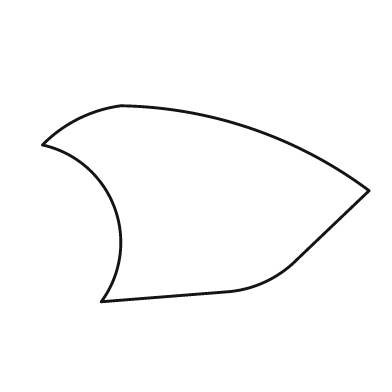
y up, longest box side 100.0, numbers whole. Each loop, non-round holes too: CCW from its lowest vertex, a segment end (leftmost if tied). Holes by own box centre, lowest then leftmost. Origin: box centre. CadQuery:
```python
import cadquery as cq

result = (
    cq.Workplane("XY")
    .moveTo(-32.0, -30.0)
    .lineTo(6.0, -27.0)
    .threePointArc((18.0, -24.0), (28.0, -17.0))
    .lineTo(50.0, 4.0)
    .threePointArc((14.0, 23.0), (-26.0, 30.0))
    .threePointArc((-39.0, 26.0), (-50.0, 18.0))
    .threePointArc((-28.0, -1.0), (-32.0, -30.0))
    .close()
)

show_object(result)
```